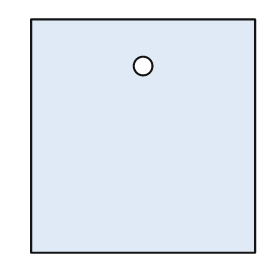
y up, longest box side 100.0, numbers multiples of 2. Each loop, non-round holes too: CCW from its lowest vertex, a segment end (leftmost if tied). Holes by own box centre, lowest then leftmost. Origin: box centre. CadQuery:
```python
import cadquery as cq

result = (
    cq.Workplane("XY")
    .moveTo(-48.0, -50.0)
    .lineTo(48.0, -50.0)
    .lineTo(48.0, 50.0)
    .lineTo(-48.0, 50.0)
    .close()
    .moveTo(0.0, 30.0)
    .circle(4.0)
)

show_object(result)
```